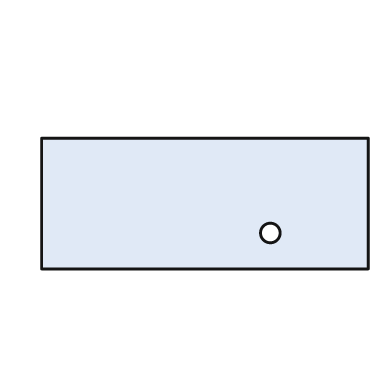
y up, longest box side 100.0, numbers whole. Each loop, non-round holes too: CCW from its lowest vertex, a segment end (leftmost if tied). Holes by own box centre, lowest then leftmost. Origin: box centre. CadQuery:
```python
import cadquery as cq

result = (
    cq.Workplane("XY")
    .moveTo(-50.0, -20.0)
    .lineTo(50.0, -20.0)
    .lineTo(50.0, 20.0)
    .lineTo(-50.0, 20.0)
    .close()
    .moveTo(20.0, -9.0)
    .circle(3.0)
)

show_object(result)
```